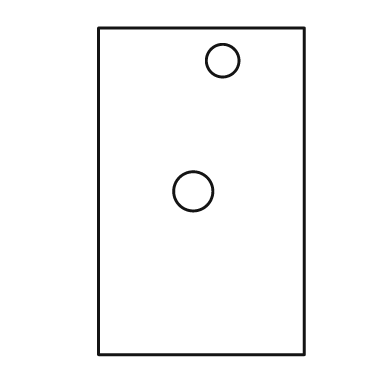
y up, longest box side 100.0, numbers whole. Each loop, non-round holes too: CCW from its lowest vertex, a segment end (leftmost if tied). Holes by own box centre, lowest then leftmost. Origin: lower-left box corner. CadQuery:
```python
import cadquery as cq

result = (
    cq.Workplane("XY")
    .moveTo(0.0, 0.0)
    .lineTo(63.0, 0.0)
    .lineTo(63.0, 100.0)
    .lineTo(0.0, 100.0)
    .close()
    .moveTo(29.0, 50.0)
    .circle(6.0)
    .moveTo(38.0, 90.0)
    .circle(5.0)
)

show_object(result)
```